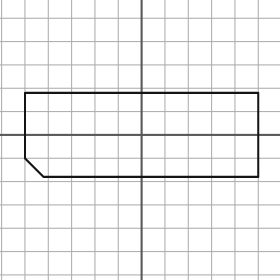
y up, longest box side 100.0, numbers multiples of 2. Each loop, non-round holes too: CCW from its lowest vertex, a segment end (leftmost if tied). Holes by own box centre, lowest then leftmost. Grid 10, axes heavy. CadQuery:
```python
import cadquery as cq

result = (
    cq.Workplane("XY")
    .moveTo(-42.0, -18.0)
    .lineTo(50.0, -18.0)
    .lineTo(50.0, 18.0)
    .lineTo(-50.0, 18.0)
    .lineTo(-50.0, -10.0)
    .close()
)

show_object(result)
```